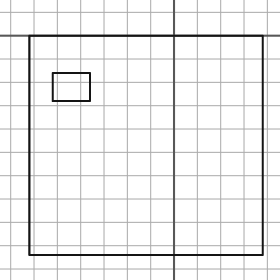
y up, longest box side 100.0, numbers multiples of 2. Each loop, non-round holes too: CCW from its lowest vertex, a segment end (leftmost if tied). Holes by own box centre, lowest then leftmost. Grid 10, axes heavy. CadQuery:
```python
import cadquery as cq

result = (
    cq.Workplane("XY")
    .moveTo(-62.0, -94.0)
    .lineTo(38.0, -94.0)
    .lineTo(38.0, 0.0)
    .lineTo(-62.0, 0.0)
    .close()
    .moveTo(-52.0, -28.0)
    .lineTo(-36.0, -28.0)
    .lineTo(-36.0, -16.0)
    .lineTo(-52.0, -16.0)
    .close()
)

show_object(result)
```